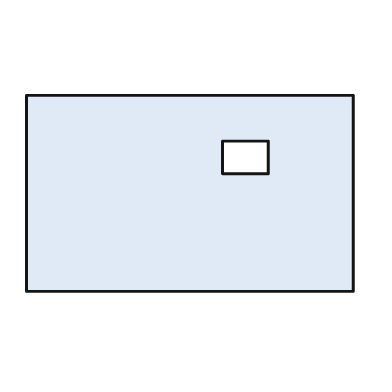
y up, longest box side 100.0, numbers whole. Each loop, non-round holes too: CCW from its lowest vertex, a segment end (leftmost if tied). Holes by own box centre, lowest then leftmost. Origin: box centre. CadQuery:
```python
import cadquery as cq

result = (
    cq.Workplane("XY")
    .moveTo(-50.0, -30.0)
    .lineTo(50.0, -30.0)
    .lineTo(50.0, 30.0)
    .lineTo(-50.0, 30.0)
    .close()
    .moveTo(10.0, 6.0)
    .lineTo(24.0, 6.0)
    .lineTo(24.0, 16.0)
    .lineTo(10.0, 16.0)
    .close()
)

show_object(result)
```